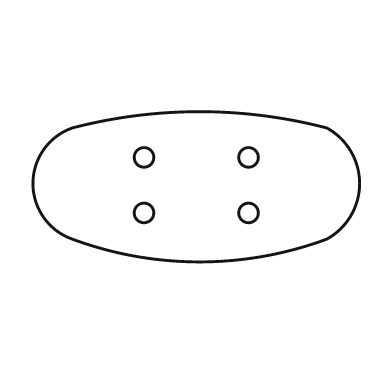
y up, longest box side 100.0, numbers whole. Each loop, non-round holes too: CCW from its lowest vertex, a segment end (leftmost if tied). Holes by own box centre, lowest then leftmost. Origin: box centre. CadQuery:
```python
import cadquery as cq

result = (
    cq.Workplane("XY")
    .moveTo(-38.0, -16.0)
    .threePointArc((1.0, -23.0), (40.0, -16.0))
    .threePointArc((50.0, 1.0), (40.0, 18.0))
    .threePointArc((1.0, 23.0), (-38.0, 18.0))
    .threePointArc((-50.0, 1.0), (-38.0, -16.0))
    .close()
    .moveTo(-16.0, -8.0)
    .circle(3.0)
    .moveTo(16.0, -8.0)
    .circle(3.0)
    .moveTo(-16.0, 9.0)
    .circle(3.0)
    .moveTo(16.0, 9.0)
    .circle(3.0)
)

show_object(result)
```